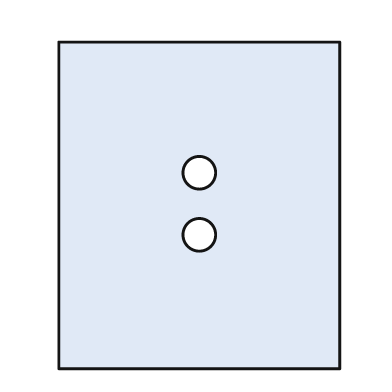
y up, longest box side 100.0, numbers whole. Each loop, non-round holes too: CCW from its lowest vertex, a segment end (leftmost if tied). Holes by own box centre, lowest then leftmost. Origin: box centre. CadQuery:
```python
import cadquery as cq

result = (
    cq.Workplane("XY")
    .moveTo(-43.0, -50.0)
    .lineTo(43.0, -50.0)
    .lineTo(43.0, 50.0)
    .lineTo(-43.0, 50.0)
    .close()
    .moveTo(0.0, -9.0)
    .circle(5.0)
    .moveTo(0.0, 10.0)
    .circle(5.0)
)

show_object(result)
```